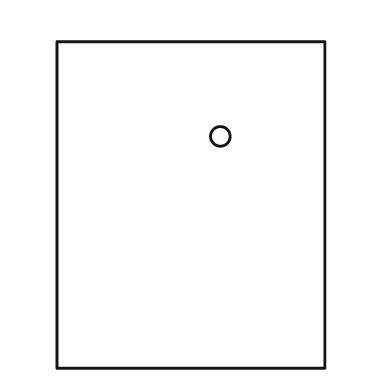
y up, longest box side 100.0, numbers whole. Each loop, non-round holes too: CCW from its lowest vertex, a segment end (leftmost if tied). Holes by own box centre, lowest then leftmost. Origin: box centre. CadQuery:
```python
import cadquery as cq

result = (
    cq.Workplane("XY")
    .moveTo(-41.0, -50.0)
    .lineTo(41.0, -50.0)
    .lineTo(41.0, 50.0)
    .lineTo(-41.0, 50.0)
    .close()
    .moveTo(9.0, 21.0)
    .circle(3.0)
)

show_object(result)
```